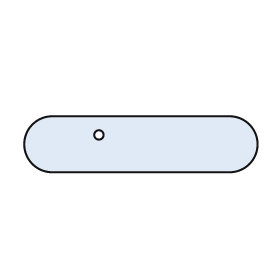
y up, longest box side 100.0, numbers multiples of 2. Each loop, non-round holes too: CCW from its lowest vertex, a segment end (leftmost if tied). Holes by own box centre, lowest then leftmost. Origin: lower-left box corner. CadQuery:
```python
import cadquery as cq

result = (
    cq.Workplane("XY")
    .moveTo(12.0, 0.0)
    .lineTo(88.0, 0.0)
    .threePointArc((100.0, 12.0), (88.0, 24.0))
    .lineTo(12.0, 24.0)
    .threePointArc((0.0, 12.0), (12.0, 0.0))
    .close()
    .moveTo(32.0, 16.0)
    .circle(2.0)
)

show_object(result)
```